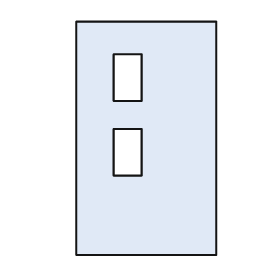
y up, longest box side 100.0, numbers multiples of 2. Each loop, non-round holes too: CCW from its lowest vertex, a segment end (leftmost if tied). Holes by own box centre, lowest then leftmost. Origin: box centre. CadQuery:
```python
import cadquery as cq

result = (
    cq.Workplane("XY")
    .moveTo(-30.0, -50.0)
    .lineTo(30.0, -50.0)
    .lineTo(30.0, 50.0)
    .lineTo(-30.0, 50.0)
    .close()
    .moveTo(-14.0, -16.0)
    .lineTo(-2.0, -16.0)
    .lineTo(-2.0, 4.0)
    .lineTo(-14.0, 4.0)
    .close()
    .moveTo(-14.0, 16.0)
    .lineTo(-2.0, 16.0)
    .lineTo(-2.0, 36.0)
    .lineTo(-14.0, 36.0)
    .close()
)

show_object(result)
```